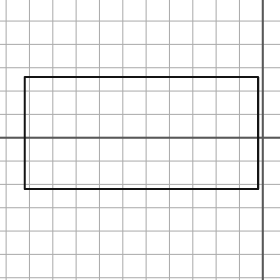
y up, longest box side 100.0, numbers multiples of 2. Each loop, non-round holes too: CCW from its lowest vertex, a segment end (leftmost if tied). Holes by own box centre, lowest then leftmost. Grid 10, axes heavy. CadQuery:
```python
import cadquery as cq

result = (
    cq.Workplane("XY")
    .moveTo(-102.0, -22.0)
    .lineTo(-2.0, -22.0)
    .lineTo(-2.0, 26.0)
    .lineTo(-102.0, 26.0)
    .close()
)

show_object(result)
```